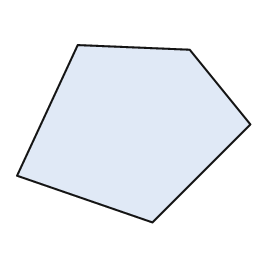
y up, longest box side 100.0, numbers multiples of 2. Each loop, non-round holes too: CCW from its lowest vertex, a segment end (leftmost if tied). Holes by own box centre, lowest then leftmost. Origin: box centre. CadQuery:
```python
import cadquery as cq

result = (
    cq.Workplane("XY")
    .moveTo(8.0, -38.0)
    .lineTo(50.0, 4.0)
    .lineTo(24.0, 36.0)
    .lineTo(-24.0, 38.0)
    .lineTo(-50.0, -18.0)
    .close()
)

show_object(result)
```